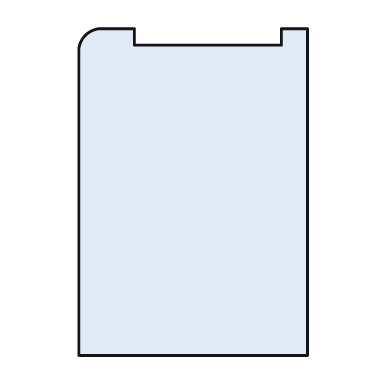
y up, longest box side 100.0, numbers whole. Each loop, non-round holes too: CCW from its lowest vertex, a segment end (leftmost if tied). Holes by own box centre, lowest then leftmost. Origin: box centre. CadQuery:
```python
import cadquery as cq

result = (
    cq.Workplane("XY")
    .moveTo(-35.0, -50.0)
    .lineTo(35.0, -50.0)
    .lineTo(35.0, 50.0)
    .lineTo(27.0, 50.0)
    .lineTo(27.0, 45.0)
    .lineTo(-18.0, 45.0)
    .lineTo(-18.0, 50.0)
    .lineTo(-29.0, 50.0)
    .threePointArc((-33.0, 48.0), (-35.0, 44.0))
    .close()
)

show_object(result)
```